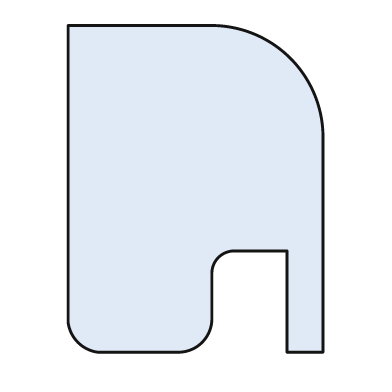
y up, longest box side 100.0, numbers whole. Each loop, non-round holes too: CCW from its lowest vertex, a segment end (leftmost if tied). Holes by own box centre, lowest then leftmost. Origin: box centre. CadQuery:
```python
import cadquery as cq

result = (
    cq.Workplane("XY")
    .moveTo(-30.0, -50.0)
    .lineTo(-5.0, -50.0)
    .threePointArc((2.0, -47.0), (5.0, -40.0))
    .lineTo(5.0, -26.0)
    .threePointArc((7.0, -21.0), (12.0, -19.0))
    .lineTo(28.0, -19.0)
    .lineTo(28.0, -50.0)
    .lineTo(39.0, -50.0)
    .lineTo(39.0, 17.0)
    .threePointArc((29.0, 40.0), (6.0, 50.0))
    .lineTo(-39.0, 50.0)
    .lineTo(-39.0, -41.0)
    .threePointArc((-36.0, -47.0), (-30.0, -50.0))
    .close()
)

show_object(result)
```